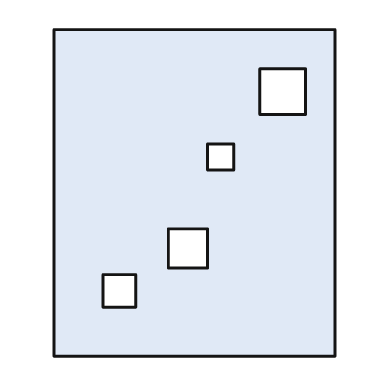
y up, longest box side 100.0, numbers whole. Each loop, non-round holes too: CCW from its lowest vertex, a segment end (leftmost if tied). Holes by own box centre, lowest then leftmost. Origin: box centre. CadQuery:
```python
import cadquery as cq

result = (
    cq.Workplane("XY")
    .moveTo(-43.0, -50.0)
    .lineTo(43.0, -50.0)
    .lineTo(43.0, 50.0)
    .lineTo(-43.0, 50.0)
    .close()
    .moveTo(-28.0, -35.0)
    .lineTo(-18.0, -35.0)
    .lineTo(-18.0, -25.0)
    .lineTo(-28.0, -25.0)
    .close()
    .moveTo(-8.0, -23.0)
    .lineTo(4.0, -23.0)
    .lineTo(4.0, -11.0)
    .lineTo(-8.0, -11.0)
    .close()
    .moveTo(4.0, 7.0)
    .lineTo(12.0, 7.0)
    .lineTo(12.0, 15.0)
    .lineTo(4.0, 15.0)
    .close()
    .moveTo(20.0, 24.0)
    .lineTo(34.0, 24.0)
    .lineTo(34.0, 38.0)
    .lineTo(20.0, 38.0)
    .close()
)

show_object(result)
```